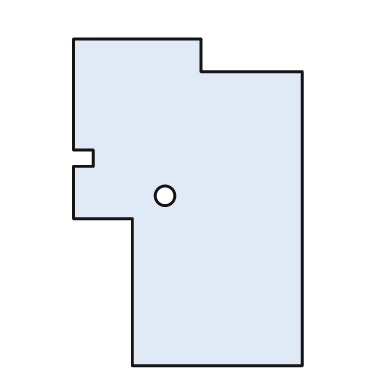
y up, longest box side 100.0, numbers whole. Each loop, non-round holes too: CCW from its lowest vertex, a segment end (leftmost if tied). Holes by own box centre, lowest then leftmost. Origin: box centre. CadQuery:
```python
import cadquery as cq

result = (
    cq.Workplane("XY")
    .moveTo(-17.0, -50.0)
    .lineTo(35.0, -50.0)
    .lineTo(35.0, 40.0)
    .lineTo(4.0, 40.0)
    .lineTo(4.0, 50.0)
    .lineTo(-35.0, 50.0)
    .lineTo(-35.0, 16.0)
    .lineTo(-29.0, 16.0)
    .lineTo(-29.0, 11.0)
    .lineTo(-35.0, 11.0)
    .lineTo(-35.0, -5.0)
    .lineTo(-17.0, -5.0)
    .close()
    .moveTo(-7.0, 2.0)
    .circle(3.0)
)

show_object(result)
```